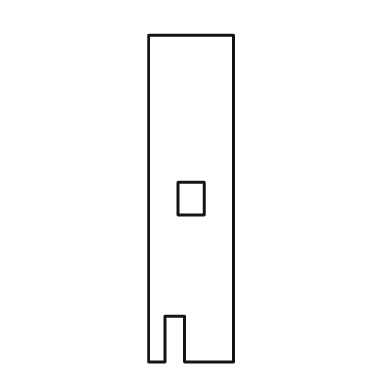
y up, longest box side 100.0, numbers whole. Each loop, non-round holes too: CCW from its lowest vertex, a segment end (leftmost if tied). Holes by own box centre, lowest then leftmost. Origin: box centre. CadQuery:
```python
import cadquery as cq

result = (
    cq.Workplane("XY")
    .moveTo(-13.0, -50.0)
    .lineTo(-8.0, -50.0)
    .lineTo(-8.0, -36.0)
    .lineTo(-2.0, -36.0)
    .lineTo(-2.0, -50.0)
    .lineTo(13.0, -50.0)
    .lineTo(13.0, 50.0)
    .lineTo(-13.0, 50.0)
    .close()
    .moveTo(-4.0, -5.0)
    .lineTo(4.0, -5.0)
    .lineTo(4.0, 5.0)
    .lineTo(-4.0, 5.0)
    .close()
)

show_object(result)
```